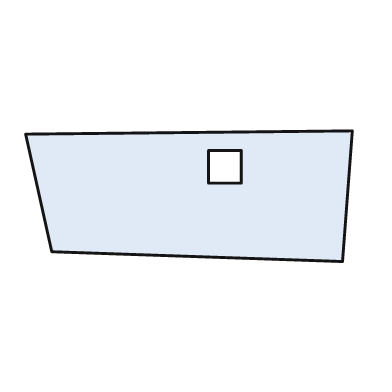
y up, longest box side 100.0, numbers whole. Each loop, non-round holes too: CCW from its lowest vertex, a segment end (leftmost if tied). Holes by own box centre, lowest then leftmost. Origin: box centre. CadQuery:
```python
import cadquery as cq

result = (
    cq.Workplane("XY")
    .moveTo(47.0, -20.0)
    .lineTo(50.0, 20.0)
    .lineTo(-50.0, 19.0)
    .lineTo(-42.0, -17.0)
    .close()
    .moveTo(6.0, 4.0)
    .lineTo(16.0, 4.0)
    .lineTo(16.0, 14.0)
    .lineTo(6.0, 14.0)
    .close()
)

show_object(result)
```